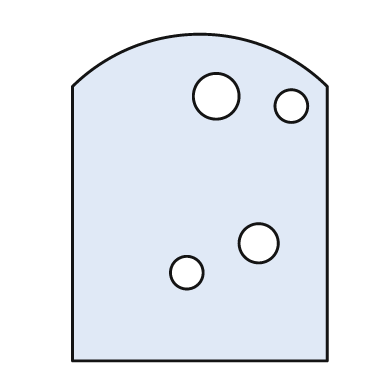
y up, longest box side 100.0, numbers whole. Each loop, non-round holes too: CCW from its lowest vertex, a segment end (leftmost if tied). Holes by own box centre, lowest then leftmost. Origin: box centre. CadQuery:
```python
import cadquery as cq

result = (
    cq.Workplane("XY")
    .moveTo(-39.0, -50.0)
    .lineTo(39.0, -50.0)
    .lineTo(39.0, 34.0)
    .threePointArc((0.0, 50.0), (-39.0, 34.0))
    .close()
    .moveTo(-4.0, -23.0)
    .circle(5.0)
    .moveTo(18.0, -14.0)
    .circle(6.0)
    .moveTo(28.0, 28.0)
    .circle(5.0)
    .moveTo(5.0, 31.0)
    .circle(7.0)
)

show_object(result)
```